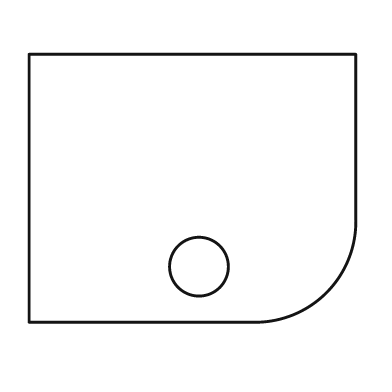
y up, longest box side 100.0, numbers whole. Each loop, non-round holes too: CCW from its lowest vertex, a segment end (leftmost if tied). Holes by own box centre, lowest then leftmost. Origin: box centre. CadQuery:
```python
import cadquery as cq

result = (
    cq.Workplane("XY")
    .moveTo(-50.0, -41.0)
    .lineTo(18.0, -41.0)
    .threePointArc((41.0, -32.0), (50.0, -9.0))
    .lineTo(50.0, 41.0)
    .lineTo(-50.0, 41.0)
    .close()
    .moveTo(2.0, -24.0)
    .circle(9.0)
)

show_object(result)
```